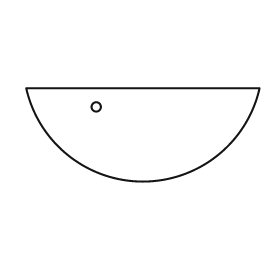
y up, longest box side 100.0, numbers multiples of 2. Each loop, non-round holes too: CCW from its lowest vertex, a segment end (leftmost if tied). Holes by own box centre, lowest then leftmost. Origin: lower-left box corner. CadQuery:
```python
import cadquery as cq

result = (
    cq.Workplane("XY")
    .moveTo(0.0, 40.0)
    .threePointArc((50.0, 0.0), (100.0, 40.0))
    .close()
    .moveTo(30.0, 32.0)
    .circle(2.0)
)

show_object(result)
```